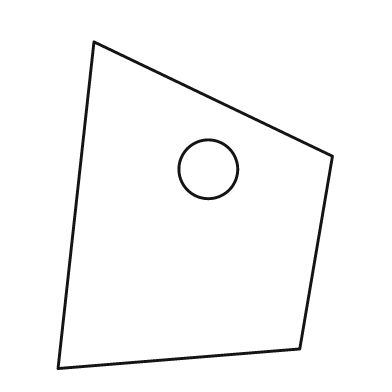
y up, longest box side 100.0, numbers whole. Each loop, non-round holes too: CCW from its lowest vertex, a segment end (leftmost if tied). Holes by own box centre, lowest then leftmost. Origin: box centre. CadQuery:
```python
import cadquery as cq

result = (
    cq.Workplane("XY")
    .moveTo(-42.0, -50.0)
    .lineTo(32.0, -44.0)
    .lineTo(42.0, 15.0)
    .lineTo(-31.0, 50.0)
    .close()
    .moveTo(4.0, 11.0)
    .circle(9.0)
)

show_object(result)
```